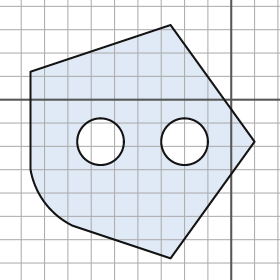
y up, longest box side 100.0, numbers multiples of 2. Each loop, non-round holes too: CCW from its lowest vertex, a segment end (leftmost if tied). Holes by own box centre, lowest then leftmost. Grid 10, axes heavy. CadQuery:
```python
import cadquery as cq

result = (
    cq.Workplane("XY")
    .moveTo(-26.0, -68.0)
    .lineTo(10.0, -18.0)
    .lineTo(-26.0, 32.0)
    .lineTo(-86.0, 12.0)
    .lineTo(-86.0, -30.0)
    .threePointArc((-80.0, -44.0), (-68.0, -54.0))
    .close()
    .moveTo(-56.0, -18.0)
    .circle(10.0)
    .moveTo(-20.0, -18.0)
    .circle(10.0)
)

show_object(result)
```